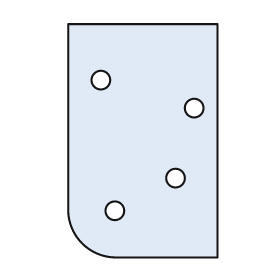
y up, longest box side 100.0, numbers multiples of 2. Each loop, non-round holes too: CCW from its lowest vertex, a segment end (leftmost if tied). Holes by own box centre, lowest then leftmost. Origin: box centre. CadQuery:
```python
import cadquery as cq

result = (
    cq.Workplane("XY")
    .moveTo(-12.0, -50.0)
    .lineTo(32.0, -50.0)
    .lineTo(32.0, 50.0)
    .lineTo(-32.0, 50.0)
    .lineTo(-32.0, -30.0)
    .threePointArc((-26.0, -44.0), (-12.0, -50.0))
    .close()
    .moveTo(-12.0, -30.0)
    .circle(4.0)
    .moveTo(14.0, -16.0)
    .circle(4.0)
    .moveTo(22.0, 14.0)
    .circle(4.0)
    .moveTo(-18.0, 26.0)
    .circle(4.0)
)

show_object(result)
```